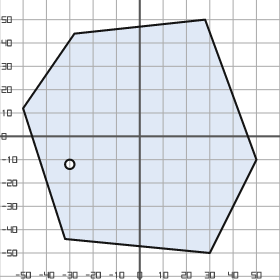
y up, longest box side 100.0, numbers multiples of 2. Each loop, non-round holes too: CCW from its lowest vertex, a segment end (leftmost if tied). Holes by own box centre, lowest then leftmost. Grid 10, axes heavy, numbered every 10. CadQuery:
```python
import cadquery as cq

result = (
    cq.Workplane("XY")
    .moveTo(30.0, -50.0)
    .lineTo(50.0, -10.0)
    .lineTo(28.0, 50.0)
    .lineTo(-28.0, 44.0)
    .lineTo(-50.0, 12.0)
    .lineTo(-32.0, -44.0)
    .close()
    .moveTo(-30.0, -12.0)
    .circle(2.0)
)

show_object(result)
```